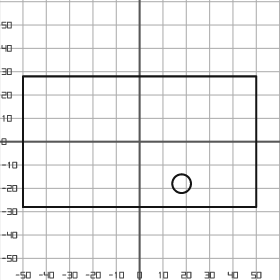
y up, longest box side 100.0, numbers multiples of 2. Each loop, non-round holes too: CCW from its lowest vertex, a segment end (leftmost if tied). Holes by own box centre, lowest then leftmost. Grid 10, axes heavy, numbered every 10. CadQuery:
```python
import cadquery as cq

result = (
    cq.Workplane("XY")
    .moveTo(-50.0, -28.0)
    .lineTo(50.0, -28.0)
    .lineTo(50.0, 28.0)
    .lineTo(-50.0, 28.0)
    .close()
    .moveTo(18.0, -18.0)
    .circle(4.0)
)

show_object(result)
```